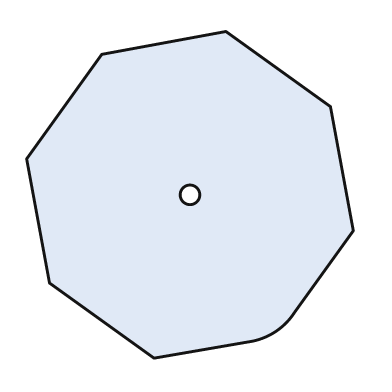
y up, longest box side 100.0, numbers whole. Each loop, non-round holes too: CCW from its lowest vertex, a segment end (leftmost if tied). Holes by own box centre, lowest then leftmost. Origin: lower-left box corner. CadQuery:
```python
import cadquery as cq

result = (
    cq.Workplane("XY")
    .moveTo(39.0, 0.0)
    .lineTo(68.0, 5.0)
    .threePointArc((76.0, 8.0), (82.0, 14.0))
    .lineTo(100.0, 39.0)
    .lineTo(93.0, 77.0)
    .lineTo(61.0, 100.0)
    .lineTo(23.0, 93.0)
    .lineTo(0.0, 61.0)
    .lineTo(7.0, 23.0)
    .close()
    .moveTo(50.0, 50.0)
    .circle(3.0)
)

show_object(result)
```